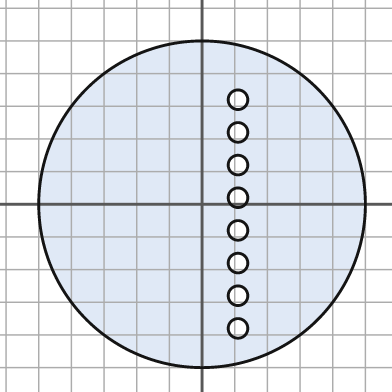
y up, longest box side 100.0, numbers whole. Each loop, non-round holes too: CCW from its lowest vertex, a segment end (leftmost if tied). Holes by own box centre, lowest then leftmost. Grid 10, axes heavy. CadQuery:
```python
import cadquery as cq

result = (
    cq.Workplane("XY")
    .moveTo(0.0, 0.0)
    .circle(50.0)
    .moveTo(11.0, -38.0)
    .circle(3.0)
    .moveTo(11.0, -28.0)
    .circle(3.0)
    .moveTo(11.0, -18.0)
    .circle(3.0)
    .moveTo(11.0, -8.0)
    .circle(3.0)
    .moveTo(11.0, 2.0)
    .circle(3.0)
    .moveTo(11.0, 12.0)
    .circle(3.0)
    .moveTo(11.0, 22.0)
    .circle(3.0)
    .moveTo(11.0, 32.0)
    .circle(3.0)
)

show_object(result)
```